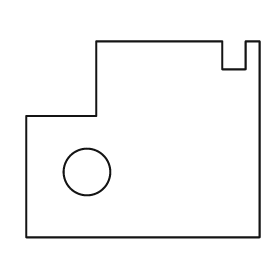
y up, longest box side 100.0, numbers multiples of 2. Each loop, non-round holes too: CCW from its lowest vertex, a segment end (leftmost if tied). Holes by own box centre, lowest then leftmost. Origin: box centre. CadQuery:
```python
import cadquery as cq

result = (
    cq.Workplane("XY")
    .moveTo(-50.0, -42.0)
    .lineTo(50.0, -42.0)
    .lineTo(50.0, 42.0)
    .lineTo(44.0, 42.0)
    .lineTo(44.0, 30.0)
    .lineTo(34.0, 30.0)
    .lineTo(34.0, 42.0)
    .lineTo(-20.0, 42.0)
    .lineTo(-20.0, 10.0)
    .lineTo(-50.0, 10.0)
    .close()
    .moveTo(-24.0, -14.0)
    .circle(10.0)
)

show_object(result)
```